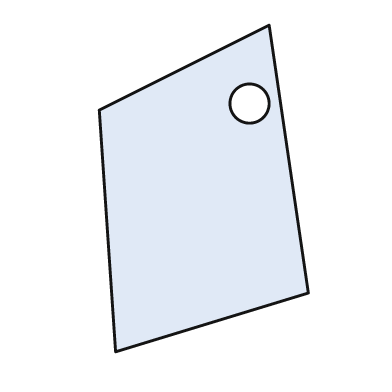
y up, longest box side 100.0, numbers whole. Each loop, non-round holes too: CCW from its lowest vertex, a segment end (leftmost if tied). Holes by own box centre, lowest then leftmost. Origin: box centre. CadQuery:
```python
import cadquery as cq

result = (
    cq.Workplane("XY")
    .moveTo(-27.0, -50.0)
    .lineTo(32.0, -32.0)
    .lineTo(20.0, 50.0)
    .lineTo(-32.0, 24.0)
    .close()
    .moveTo(14.0, 26.0)
    .circle(6.0)
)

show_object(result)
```